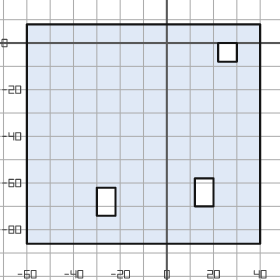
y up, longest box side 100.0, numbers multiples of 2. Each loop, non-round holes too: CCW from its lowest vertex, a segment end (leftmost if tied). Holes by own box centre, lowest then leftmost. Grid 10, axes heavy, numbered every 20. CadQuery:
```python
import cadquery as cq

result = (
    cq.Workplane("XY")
    .moveTo(-60.0, -86.0)
    .lineTo(40.0, -86.0)
    .lineTo(40.0, 8.0)
    .lineTo(-60.0, 8.0)
    .close()
    .moveTo(-30.0, -74.0)
    .lineTo(-22.0, -74.0)
    .lineTo(-22.0, -62.0)
    .lineTo(-30.0, -62.0)
    .close()
    .moveTo(12.0, -70.0)
    .lineTo(20.0, -70.0)
    .lineTo(20.0, -58.0)
    .lineTo(12.0, -58.0)
    .close()
    .moveTo(22.0, -8.0)
    .lineTo(30.0, -8.0)
    .lineTo(30.0, 0.0)
    .lineTo(22.0, 0.0)
    .close()
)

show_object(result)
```